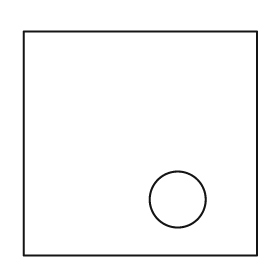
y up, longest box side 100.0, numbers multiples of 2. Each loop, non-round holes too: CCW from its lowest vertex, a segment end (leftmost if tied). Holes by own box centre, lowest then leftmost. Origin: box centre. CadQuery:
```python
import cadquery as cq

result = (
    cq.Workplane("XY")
    .moveTo(-50.0, -48.0)
    .lineTo(50.0, -48.0)
    .lineTo(50.0, 48.0)
    .lineTo(-50.0, 48.0)
    .close()
    .moveTo(16.0, -24.0)
    .circle(12.0)
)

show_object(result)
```